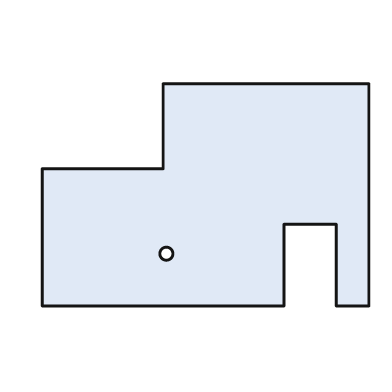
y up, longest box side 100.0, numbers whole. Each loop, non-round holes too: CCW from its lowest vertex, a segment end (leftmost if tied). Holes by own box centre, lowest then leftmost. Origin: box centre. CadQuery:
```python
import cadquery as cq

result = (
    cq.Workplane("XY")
    .moveTo(-50.0, -34.0)
    .lineTo(24.0, -34.0)
    .lineTo(24.0, -9.0)
    .lineTo(40.0, -9.0)
    .lineTo(40.0, -34.0)
    .lineTo(50.0, -34.0)
    .lineTo(50.0, 34.0)
    .lineTo(-13.0, 34.0)
    .lineTo(-13.0, 8.0)
    .lineTo(-50.0, 8.0)
    .close()
    .moveTo(-12.0, -18.0)
    .circle(2.0)
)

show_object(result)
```